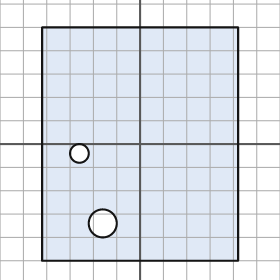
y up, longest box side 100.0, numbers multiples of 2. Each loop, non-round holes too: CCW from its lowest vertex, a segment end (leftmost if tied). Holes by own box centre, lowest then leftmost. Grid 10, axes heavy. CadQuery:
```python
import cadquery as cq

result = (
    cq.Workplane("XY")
    .moveTo(-42.0, -50.0)
    .lineTo(42.0, -50.0)
    .lineTo(42.0, 50.0)
    .lineTo(-42.0, 50.0)
    .close()
    .moveTo(-16.0, -34.0)
    .circle(6.0)
    .moveTo(-26.0, -4.0)
    .circle(4.0)
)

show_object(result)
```